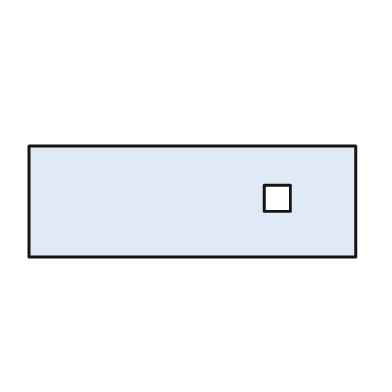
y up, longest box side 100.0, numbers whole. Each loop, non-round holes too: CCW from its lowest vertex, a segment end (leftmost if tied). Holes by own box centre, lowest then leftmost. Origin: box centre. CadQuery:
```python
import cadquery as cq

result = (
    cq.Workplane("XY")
    .moveTo(-50.0, -17.0)
    .lineTo(50.0, -17.0)
    .lineTo(50.0, 17.0)
    .lineTo(-50.0, 17.0)
    .close()
    .moveTo(22.0, -3.0)
    .lineTo(30.0, -3.0)
    .lineTo(30.0, 5.0)
    .lineTo(22.0, 5.0)
    .close()
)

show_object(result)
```